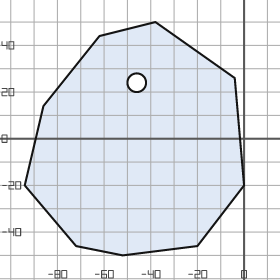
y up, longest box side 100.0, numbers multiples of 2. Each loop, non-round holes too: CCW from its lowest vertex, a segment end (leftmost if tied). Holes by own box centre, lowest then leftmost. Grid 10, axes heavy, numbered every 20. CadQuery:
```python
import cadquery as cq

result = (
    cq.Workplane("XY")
    .moveTo(-52.0, -50.0)
    .lineTo(-20.0, -46.0)
    .lineTo(0.0, -20.0)
    .lineTo(-4.0, 26.0)
    .lineTo(-38.0, 50.0)
    .lineTo(-62.0, 44.0)
    .lineTo(-86.0, 14.0)
    .lineTo(-94.0, -20.0)
    .lineTo(-72.0, -46.0)
    .close()
    .moveTo(-46.0, 24.0)
    .circle(4.0)
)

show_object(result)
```